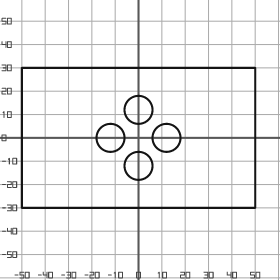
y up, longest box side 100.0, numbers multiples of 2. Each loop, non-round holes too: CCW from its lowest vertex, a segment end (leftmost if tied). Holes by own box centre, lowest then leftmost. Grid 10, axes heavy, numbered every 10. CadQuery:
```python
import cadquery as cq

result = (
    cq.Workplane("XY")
    .moveTo(-50.0, -30.0)
    .lineTo(50.0, -30.0)
    .lineTo(50.0, 30.0)
    .lineTo(-50.0, 30.0)
    .close()
    .moveTo(0.0, -12.0)
    .circle(6.0)
    .moveTo(-12.0, 0.0)
    .circle(6.0)
    .moveTo(12.0, 0.0)
    .circle(6.0)
    .moveTo(0.0, 12.0)
    .circle(6.0)
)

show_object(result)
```